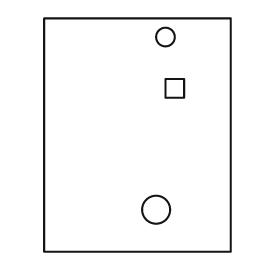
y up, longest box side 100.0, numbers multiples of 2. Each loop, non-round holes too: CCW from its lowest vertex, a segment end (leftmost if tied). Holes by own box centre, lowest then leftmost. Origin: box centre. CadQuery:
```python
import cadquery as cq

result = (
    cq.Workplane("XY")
    .moveTo(-40.0, -50.0)
    .lineTo(40.0, -50.0)
    .lineTo(40.0, 50.0)
    .lineTo(-40.0, 50.0)
    .close()
    .moveTo(8.0, -32.0)
    .circle(6.0)
    .moveTo(12.0, 16.0)
    .lineTo(20.0, 16.0)
    .lineTo(20.0, 24.0)
    .lineTo(12.0, 24.0)
    .close()
    .moveTo(12.0, 42.0)
    .circle(4.0)
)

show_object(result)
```